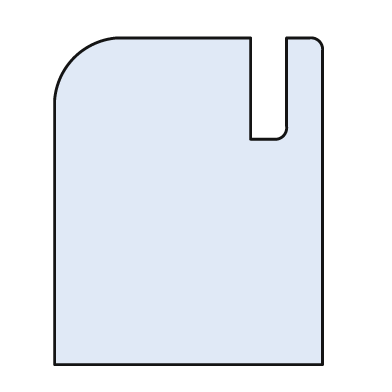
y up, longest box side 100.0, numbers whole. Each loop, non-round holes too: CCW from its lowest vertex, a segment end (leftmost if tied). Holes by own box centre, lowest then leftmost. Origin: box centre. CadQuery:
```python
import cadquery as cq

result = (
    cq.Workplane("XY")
    .moveTo(-41.0, -50.0)
    .lineTo(41.0, -50.0)
    .lineTo(41.0, 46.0)
    .threePointArc((40.0, 49.0), (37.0, 50.0))
    .lineTo(30.0, 50.0)
    .lineTo(30.0, 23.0)
    .threePointArc((29.0, 20.0), (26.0, 19.0))
    .lineTo(19.0, 19.0)
    .lineTo(19.0, 50.0)
    .lineTo(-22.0, 50.0)
    .threePointArc((-35.0, 44.0), (-41.0, 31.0))
    .close()
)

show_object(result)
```